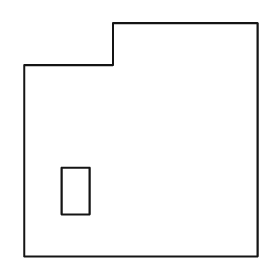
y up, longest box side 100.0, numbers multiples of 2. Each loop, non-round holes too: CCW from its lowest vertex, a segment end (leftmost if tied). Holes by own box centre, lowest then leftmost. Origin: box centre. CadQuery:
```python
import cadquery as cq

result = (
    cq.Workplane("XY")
    .moveTo(-50.0, -50.0)
    .lineTo(50.0, -50.0)
    .lineTo(50.0, 50.0)
    .lineTo(-12.0, 50.0)
    .lineTo(-12.0, 32.0)
    .lineTo(-50.0, 32.0)
    .close()
    .moveTo(-34.0, -32.0)
    .lineTo(-22.0, -32.0)
    .lineTo(-22.0, -12.0)
    .lineTo(-34.0, -12.0)
    .close()
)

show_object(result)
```